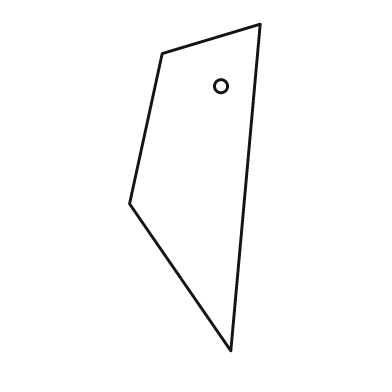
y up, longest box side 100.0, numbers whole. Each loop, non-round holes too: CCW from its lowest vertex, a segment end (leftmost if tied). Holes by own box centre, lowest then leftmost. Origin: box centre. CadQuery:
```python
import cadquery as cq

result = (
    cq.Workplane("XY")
    .moveTo(11.0, -50.0)
    .lineTo(20.0, 50.0)
    .lineTo(-10.0, 41.0)
    .lineTo(-20.0, -5.0)
    .close()
    .moveTo(8.0, 31.0)
    .circle(2.0)
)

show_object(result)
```